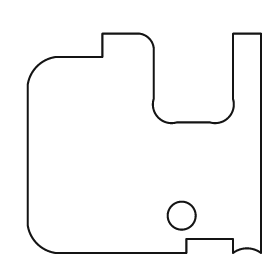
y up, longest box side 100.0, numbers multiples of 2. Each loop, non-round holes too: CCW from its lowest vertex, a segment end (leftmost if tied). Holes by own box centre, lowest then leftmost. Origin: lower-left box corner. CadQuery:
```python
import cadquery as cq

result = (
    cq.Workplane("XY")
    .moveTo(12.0, 0.0)
    .lineTo(68.0, 0.0)
    .lineTo(68.0, 6.0)
    .lineTo(88.0, 6.0)
    .lineTo(88.0, 0.0)
    .threePointArc((94.0, 2.0), (100.0, 0.0))
    .lineTo(100.0, 94.0)
    .lineTo(88.0, 94.0)
    .lineTo(88.0, 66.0)
    .threePointArc((86.0, 58.0), (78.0, 56.0))
    .lineTo(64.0, 56.0)
    .threePointArc((56.0, 58.0), (54.0, 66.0))
    .lineTo(54.0, 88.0)
    .threePointArc((52.0, 92.0), (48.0, 94.0))
    .lineTo(32.0, 94.0)
    .lineTo(32.0, 84.0)
    .lineTo(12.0, 84.0)
    .threePointArc((4.0, 80.0), (0.0, 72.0))
    .lineTo(0.0, 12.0)
    .threePointArc((4.0, 4.0), (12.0, 0.0))
    .close()
    .moveTo(66.0, 16.0)
    .circle(6.0)
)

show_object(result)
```